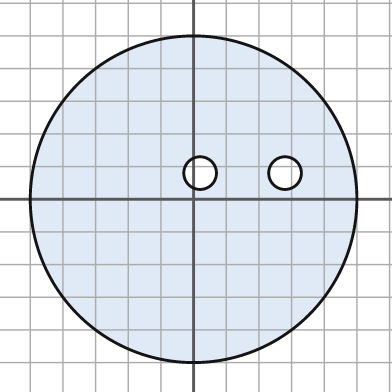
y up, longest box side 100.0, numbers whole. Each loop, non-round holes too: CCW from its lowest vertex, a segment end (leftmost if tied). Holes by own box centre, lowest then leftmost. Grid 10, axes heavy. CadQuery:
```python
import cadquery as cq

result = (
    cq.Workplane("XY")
    .moveTo(0.0, 0.0)
    .circle(50.0)
    .moveTo(2.0, 8.0)
    .circle(5.0)
    .moveTo(28.0, 8.0)
    .circle(5.0)
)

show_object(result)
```